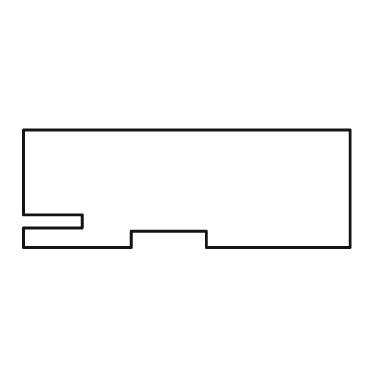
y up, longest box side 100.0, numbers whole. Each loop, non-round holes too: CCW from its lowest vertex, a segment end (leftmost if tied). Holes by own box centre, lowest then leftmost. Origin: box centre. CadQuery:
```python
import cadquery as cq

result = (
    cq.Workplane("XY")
    .moveTo(-50.0, -18.0)
    .lineTo(-17.0, -18.0)
    .lineTo(-17.0, -13.0)
    .lineTo(6.0, -13.0)
    .lineTo(6.0, -18.0)
    .lineTo(50.0, -18.0)
    .lineTo(50.0, 18.0)
    .lineTo(-50.0, 18.0)
    .lineTo(-50.0, -8.0)
    .lineTo(-32.0, -8.0)
    .lineTo(-32.0, -12.0)
    .lineTo(-50.0, -12.0)
    .close()
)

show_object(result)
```